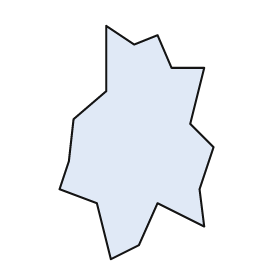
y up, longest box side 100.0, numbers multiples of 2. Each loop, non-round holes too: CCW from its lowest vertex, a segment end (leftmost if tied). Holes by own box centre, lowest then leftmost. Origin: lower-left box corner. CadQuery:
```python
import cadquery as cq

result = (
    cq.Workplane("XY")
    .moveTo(22.0, 0.0)
    .lineTo(34.0, 6.0)
    .lineTo(42.0, 24.0)
    .lineTo(62.0, 14.0)
    .lineTo(60.0, 30.0)
    .lineTo(66.0, 48.0)
    .lineTo(56.0, 58.0)
    .lineTo(62.0, 82.0)
    .lineTo(48.0, 82.0)
    .lineTo(42.0, 96.0)
    .lineTo(32.0, 92.0)
    .lineTo(20.0, 100.0)
    .lineTo(20.0, 72.0)
    .lineTo(6.0, 60.0)
    .lineTo(4.0, 42.0)
    .lineTo(0.0, 30.0)
    .lineTo(16.0, 24.0)
    .close()
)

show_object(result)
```